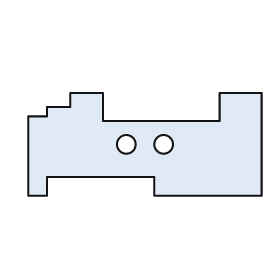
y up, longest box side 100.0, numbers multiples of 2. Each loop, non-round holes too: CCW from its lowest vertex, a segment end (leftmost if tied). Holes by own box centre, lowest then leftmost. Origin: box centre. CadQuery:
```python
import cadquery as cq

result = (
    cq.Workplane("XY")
    .moveTo(-50.0, -22.0)
    .lineTo(-42.0, -22.0)
    .lineTo(-42.0, -14.0)
    .lineTo(4.0, -14.0)
    .lineTo(4.0, -22.0)
    .lineTo(50.0, -22.0)
    .lineTo(50.0, 22.0)
    .lineTo(32.0, 22.0)
    .lineTo(32.0, 10.0)
    .lineTo(-18.0, 10.0)
    .lineTo(-18.0, 22.0)
    .lineTo(-32.0, 22.0)
    .lineTo(-32.0, 16.0)
    .lineTo(-42.0, 16.0)
    .lineTo(-42.0, 12.0)
    .lineTo(-50.0, 12.0)
    .close()
    .moveTo(-8.0, 0.0)
    .circle(4.0)
    .moveTo(8.0, 0.0)
    .circle(4.0)
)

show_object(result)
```